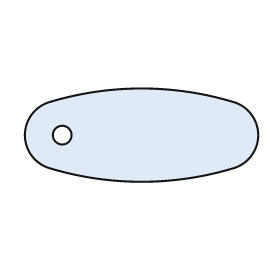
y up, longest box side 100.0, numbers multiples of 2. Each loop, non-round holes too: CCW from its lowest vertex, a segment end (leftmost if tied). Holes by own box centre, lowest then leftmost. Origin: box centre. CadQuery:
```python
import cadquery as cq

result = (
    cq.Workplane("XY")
    .moveTo(-40.0, -14.0)
    .threePointArc((0.0, -20.0), (40.0, -14.0))
    .threePointArc((50.0, 0.0), (40.0, 14.0))
    .threePointArc((0.0, 20.0), (-40.0, 14.0))
    .threePointArc((-50.0, 0.0), (-40.0, -14.0))
    .close()
    .moveTo(-34.0, 0.0)
    .circle(4.0)
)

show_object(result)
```